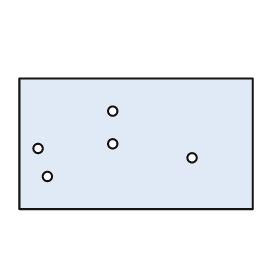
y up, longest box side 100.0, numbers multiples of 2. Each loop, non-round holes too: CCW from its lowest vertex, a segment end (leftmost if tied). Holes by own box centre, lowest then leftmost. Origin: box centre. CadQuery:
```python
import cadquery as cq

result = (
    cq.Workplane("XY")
    .moveTo(-50.0, -28.0)
    .lineTo(50.0, -28.0)
    .lineTo(50.0, 28.0)
    .lineTo(-50.0, 28.0)
    .close()
    .moveTo(-38.0, -14.0)
    .circle(2.0)
    .moveTo(24.0, -6.0)
    .circle(2.0)
    .moveTo(-42.0, -2.0)
    .circle(2.0)
    .moveTo(-10.0, 0.0)
    .circle(2.0)
    .moveTo(-10.0, 14.0)
    .circle(2.0)
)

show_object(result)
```